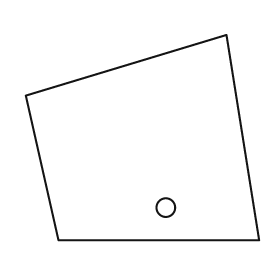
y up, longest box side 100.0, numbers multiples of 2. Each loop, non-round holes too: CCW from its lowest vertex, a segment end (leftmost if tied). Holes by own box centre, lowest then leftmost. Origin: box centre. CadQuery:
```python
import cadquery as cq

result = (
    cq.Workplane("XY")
    .moveTo(-36.0, -44.0)
    .lineTo(50.0, -44.0)
    .lineTo(36.0, 44.0)
    .lineTo(-50.0, 18.0)
    .close()
    .moveTo(10.0, -30.0)
    .circle(4.0)
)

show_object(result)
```